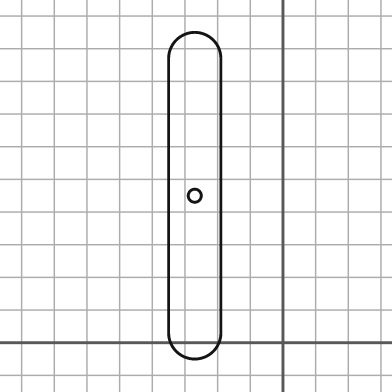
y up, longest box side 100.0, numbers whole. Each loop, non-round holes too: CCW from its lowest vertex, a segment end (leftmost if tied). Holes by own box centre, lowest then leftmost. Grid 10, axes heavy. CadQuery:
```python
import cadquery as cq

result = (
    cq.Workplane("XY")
    .moveTo(-35.0, 3.0)
    .threePointArc((-27.0, -5.0), (-19.0, 3.0))
    .lineTo(-19.0, 87.0)
    .threePointArc((-27.0, 95.0), (-35.0, 87.0))
    .close()
    .moveTo(-27.0, 45.0)
    .circle(2.0)
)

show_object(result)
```